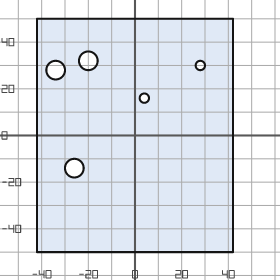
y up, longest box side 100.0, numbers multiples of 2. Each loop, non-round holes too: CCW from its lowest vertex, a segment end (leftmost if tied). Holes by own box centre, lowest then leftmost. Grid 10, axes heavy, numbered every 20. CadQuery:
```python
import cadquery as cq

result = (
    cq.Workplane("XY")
    .moveTo(-42.0, -50.0)
    .lineTo(42.0, -50.0)
    .lineTo(42.0, 50.0)
    .lineTo(-42.0, 50.0)
    .close()
    .moveTo(-26.0, -14.0)
    .circle(4.0)
    .moveTo(4.0, 16.0)
    .circle(2.0)
    .moveTo(-34.0, 28.0)
    .circle(4.0)
    .moveTo(28.0, 30.0)
    .circle(2.0)
    .moveTo(-20.0, 32.0)
    .circle(4.0)
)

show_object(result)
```